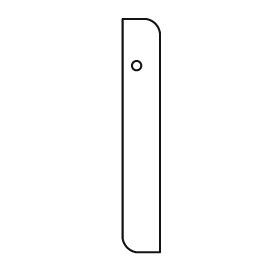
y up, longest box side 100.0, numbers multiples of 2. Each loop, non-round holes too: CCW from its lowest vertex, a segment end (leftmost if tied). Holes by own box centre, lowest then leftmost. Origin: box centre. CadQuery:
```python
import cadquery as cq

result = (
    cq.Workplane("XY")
    .moveTo(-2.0, -50.0)
    .lineTo(8.0, -50.0)
    .lineTo(8.0, 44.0)
    .threePointArc((6.0, 48.0), (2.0, 50.0))
    .lineTo(-8.0, 50.0)
    .lineTo(-8.0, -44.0)
    .threePointArc((-6.0, -48.0), (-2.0, -50.0))
    .close()
    .moveTo(-2.0, 30.0)
    .circle(2.0)
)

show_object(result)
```